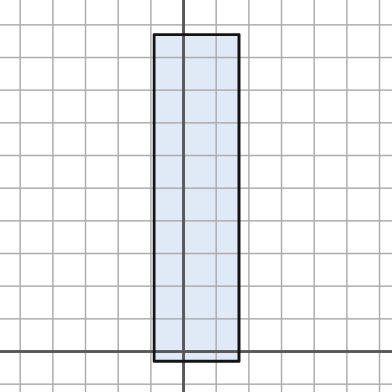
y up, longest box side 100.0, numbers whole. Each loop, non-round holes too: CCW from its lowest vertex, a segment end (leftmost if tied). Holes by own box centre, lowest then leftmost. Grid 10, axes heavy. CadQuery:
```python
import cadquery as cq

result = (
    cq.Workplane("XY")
    .moveTo(-9.0, -3.0)
    .lineTo(17.0, -3.0)
    .lineTo(17.0, 97.0)
    .lineTo(-9.0, 97.0)
    .close()
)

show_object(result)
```